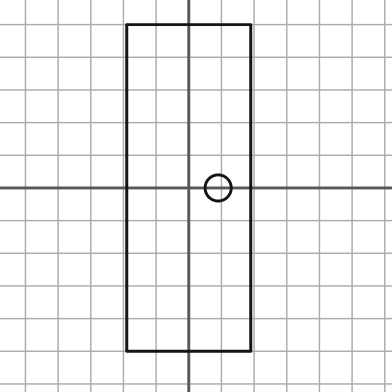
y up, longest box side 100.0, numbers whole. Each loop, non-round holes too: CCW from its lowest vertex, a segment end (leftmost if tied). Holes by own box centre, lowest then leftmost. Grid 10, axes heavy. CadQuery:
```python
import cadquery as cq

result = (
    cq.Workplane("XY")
    .moveTo(-19.0, -50.0)
    .lineTo(19.0, -50.0)
    .lineTo(19.0, 50.0)
    .lineTo(-19.0, 50.0)
    .close()
    .moveTo(9.0, 0.0)
    .circle(4.0)
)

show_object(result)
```